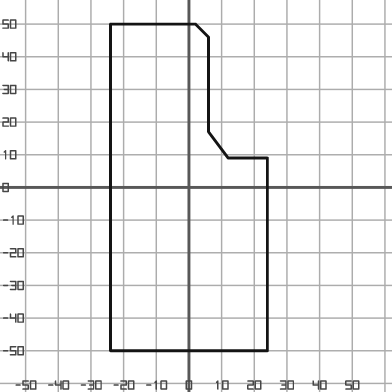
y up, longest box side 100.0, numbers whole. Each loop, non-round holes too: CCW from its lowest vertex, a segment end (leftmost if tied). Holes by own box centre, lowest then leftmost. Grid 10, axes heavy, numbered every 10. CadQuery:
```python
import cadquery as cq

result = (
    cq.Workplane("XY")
    .moveTo(-24.0, -50.0)
    .lineTo(24.0, -50.0)
    .lineTo(24.0, 9.0)
    .lineTo(12.0, 9.0)
    .lineTo(6.0, 17.0)
    .lineTo(6.0, 46.0)
    .lineTo(2.0, 50.0)
    .lineTo(-24.0, 50.0)
    .close()
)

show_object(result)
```